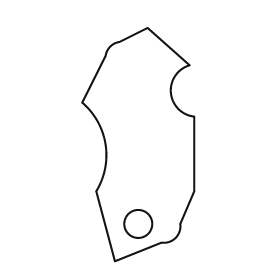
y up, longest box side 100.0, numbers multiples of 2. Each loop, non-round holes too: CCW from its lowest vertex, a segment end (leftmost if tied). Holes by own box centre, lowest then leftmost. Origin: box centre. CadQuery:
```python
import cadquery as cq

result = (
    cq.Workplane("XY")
    .moveTo(-10.0, -50.0)
    .lineTo(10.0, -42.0)
    .threePointArc((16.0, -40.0), (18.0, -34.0))
    .lineTo(24.0, -20.0)
    .lineTo(24.0, 12.0)
    .threePointArc((14.0, 22.0), (22.0, 34.0))
    .lineTo(4.0, 50.0)
    .lineTo(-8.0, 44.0)
    .threePointArc((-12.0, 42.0), (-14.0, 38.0))
    .lineTo(-24.0, 18.0)
    .threePointArc((-14.0, 0.0), (-18.0, -20.0))
    .close()
    .moveTo(0.0, -34.0)
    .circle(6.0)
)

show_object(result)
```